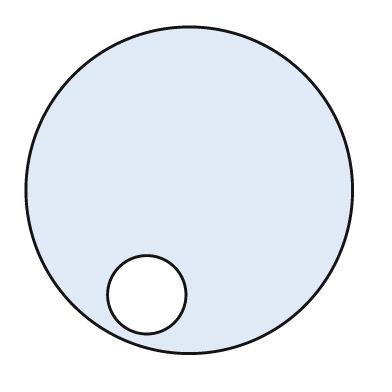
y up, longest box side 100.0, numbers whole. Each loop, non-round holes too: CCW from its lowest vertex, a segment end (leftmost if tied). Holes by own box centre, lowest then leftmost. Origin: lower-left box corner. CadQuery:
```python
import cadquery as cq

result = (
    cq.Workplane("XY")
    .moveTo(50.0, 50.0)
    .circle(50.0)
    .moveTo(37.0, 18.0)
    .circle(12.0)
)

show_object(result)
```